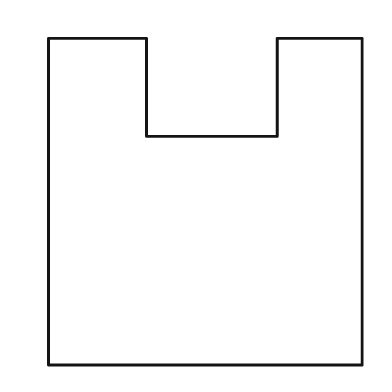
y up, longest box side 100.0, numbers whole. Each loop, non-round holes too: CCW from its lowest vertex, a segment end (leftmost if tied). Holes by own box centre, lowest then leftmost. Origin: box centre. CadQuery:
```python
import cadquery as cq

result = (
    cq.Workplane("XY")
    .moveTo(-48.0, -50.0)
    .lineTo(48.0, -50.0)
    .lineTo(48.0, 50.0)
    .lineTo(22.0, 50.0)
    .lineTo(22.0, 20.0)
    .lineTo(-18.0, 20.0)
    .lineTo(-18.0, 50.0)
    .lineTo(-48.0, 50.0)
    .close()
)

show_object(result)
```